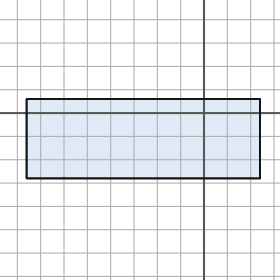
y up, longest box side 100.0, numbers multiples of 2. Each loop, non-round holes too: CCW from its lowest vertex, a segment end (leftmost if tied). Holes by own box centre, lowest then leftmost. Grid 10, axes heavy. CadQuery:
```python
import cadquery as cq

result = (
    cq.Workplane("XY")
    .moveTo(-76.0, -28.0)
    .lineTo(24.0, -28.0)
    .lineTo(24.0, 6.0)
    .lineTo(-76.0, 6.0)
    .close()
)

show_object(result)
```